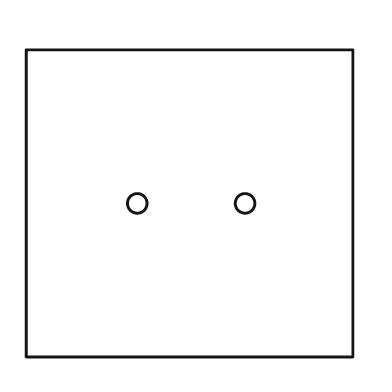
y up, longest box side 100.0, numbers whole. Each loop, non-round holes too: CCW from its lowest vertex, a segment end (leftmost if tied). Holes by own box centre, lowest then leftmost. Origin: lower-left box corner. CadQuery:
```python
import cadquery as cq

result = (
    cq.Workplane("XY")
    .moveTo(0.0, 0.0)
    .lineTo(100.0, 0.0)
    .lineTo(100.0, 94.0)
    .lineTo(0.0, 94.0)
    .close()
    .moveTo(34.0, 47.0)
    .circle(3.0)
    .moveTo(67.0, 47.0)
    .circle(3.0)
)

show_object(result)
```